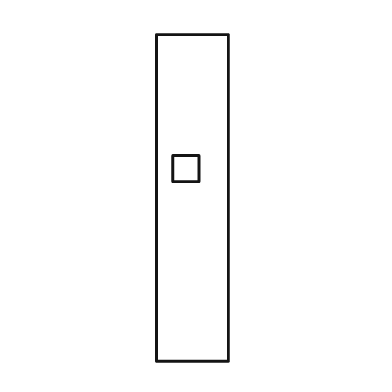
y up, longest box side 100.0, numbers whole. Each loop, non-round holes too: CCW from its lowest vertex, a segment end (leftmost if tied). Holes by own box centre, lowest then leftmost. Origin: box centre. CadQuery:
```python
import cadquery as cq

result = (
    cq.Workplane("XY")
    .moveTo(-11.0, -50.0)
    .lineTo(11.0, -50.0)
    .lineTo(11.0, 50.0)
    .lineTo(-11.0, 50.0)
    .close()
    .moveTo(-6.0, 5.0)
    .lineTo(2.0, 5.0)
    .lineTo(2.0, 13.0)
    .lineTo(-6.0, 13.0)
    .close()
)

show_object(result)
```